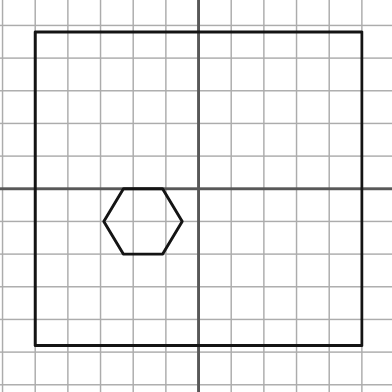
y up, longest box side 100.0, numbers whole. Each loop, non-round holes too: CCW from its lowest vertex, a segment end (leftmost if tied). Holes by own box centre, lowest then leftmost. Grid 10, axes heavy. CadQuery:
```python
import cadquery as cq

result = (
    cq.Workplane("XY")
    .moveTo(-50.0, -48.0)
    .lineTo(50.0, -48.0)
    .lineTo(50.0, 48.0)
    .lineTo(-50.0, 48.0)
    .close()
    .moveTo(-23.0, -20.0)
    .lineTo(-11.0, -20.0)
    .lineTo(-5.0, -10.0)
    .lineTo(-11.0, 0.0)
    .lineTo(-23.0, 0.0)
    .lineTo(-29.0, -10.0)
    .close()
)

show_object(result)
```